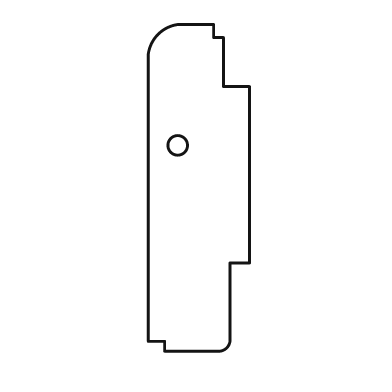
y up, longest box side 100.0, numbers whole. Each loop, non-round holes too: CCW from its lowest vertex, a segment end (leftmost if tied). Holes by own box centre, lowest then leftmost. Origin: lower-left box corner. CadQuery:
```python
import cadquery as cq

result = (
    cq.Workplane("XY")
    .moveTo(5.0, 0.0)
    .lineTo(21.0, 0.0)
    .threePointArc((24.0, 1.0), (25.0, 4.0))
    .lineTo(25.0, 27.0)
    .lineTo(31.0, 27.0)
    .lineTo(31.0, 81.0)
    .lineTo(23.0, 81.0)
    .lineTo(23.0, 96.0)
    .lineTo(20.0, 96.0)
    .lineTo(20.0, 100.0)
    .lineTo(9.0, 100.0)
    .threePointArc((3.0, 97.0), (0.0, 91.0))
    .lineTo(0.0, 3.0)
    .lineTo(5.0, 3.0)
    .close()
    .moveTo(9.0, 63.0)
    .circle(3.0)
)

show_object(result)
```